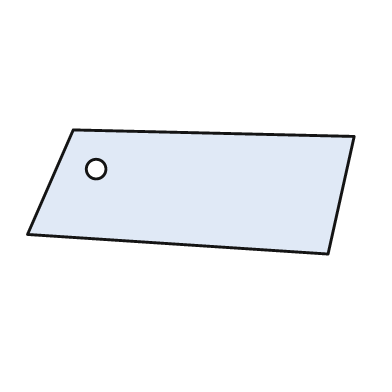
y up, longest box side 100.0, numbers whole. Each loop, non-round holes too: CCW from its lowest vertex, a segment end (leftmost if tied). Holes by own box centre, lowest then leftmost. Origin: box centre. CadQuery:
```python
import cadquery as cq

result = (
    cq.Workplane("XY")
    .moveTo(42.0, -19.0)
    .lineTo(50.0, 17.0)
    .lineTo(-36.0, 19.0)
    .lineTo(-50.0, -13.0)
    .close()
    .moveTo(-29.0, 7.0)
    .circle(3.0)
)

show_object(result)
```